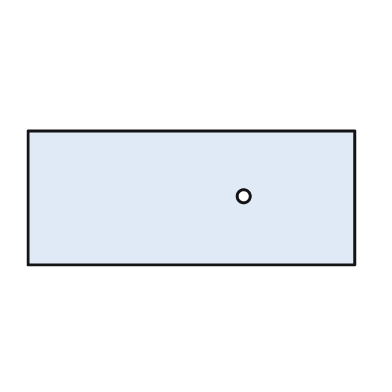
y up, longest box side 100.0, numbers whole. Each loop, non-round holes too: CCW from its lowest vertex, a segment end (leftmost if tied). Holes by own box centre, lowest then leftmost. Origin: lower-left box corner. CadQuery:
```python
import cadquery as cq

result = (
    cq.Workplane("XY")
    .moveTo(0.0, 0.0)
    .lineTo(100.0, 0.0)
    .lineTo(100.0, 41.0)
    .lineTo(0.0, 41.0)
    .close()
    .moveTo(66.0, 21.0)
    .circle(2.0)
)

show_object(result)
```